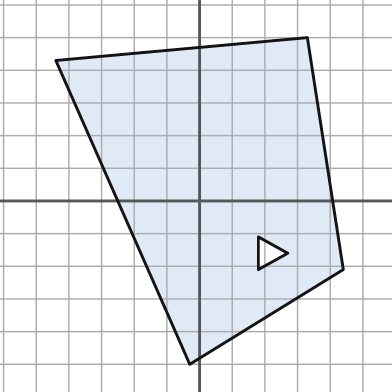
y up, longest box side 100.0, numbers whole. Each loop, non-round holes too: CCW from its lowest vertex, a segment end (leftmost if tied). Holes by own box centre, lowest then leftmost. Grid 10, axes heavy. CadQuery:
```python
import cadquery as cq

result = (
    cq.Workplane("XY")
    .moveTo(-3.0, -50.0)
    .lineTo(44.0, -21.0)
    .lineTo(33.0, 50.0)
    .lineTo(-44.0, 43.0)
    .close()
    .moveTo(18.0, -21.0)
    .lineTo(27.0, -16.0)
    .lineTo(18.0, -11.0)
    .close()
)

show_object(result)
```